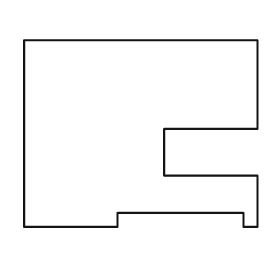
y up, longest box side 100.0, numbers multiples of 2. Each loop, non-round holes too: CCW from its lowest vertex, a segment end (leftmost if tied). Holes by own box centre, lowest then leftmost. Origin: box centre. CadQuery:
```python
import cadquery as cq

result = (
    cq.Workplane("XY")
    .moveTo(-50.0, -40.0)
    .lineTo(-10.0, -40.0)
    .lineTo(-10.0, -34.0)
    .lineTo(44.0, -34.0)
    .lineTo(44.0, -40.0)
    .lineTo(50.0, -40.0)
    .lineTo(50.0, -18.0)
    .lineTo(10.0, -18.0)
    .lineTo(10.0, 2.0)
    .lineTo(50.0, 2.0)
    .lineTo(50.0, 40.0)
    .lineTo(-50.0, 40.0)
    .close()
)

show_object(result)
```